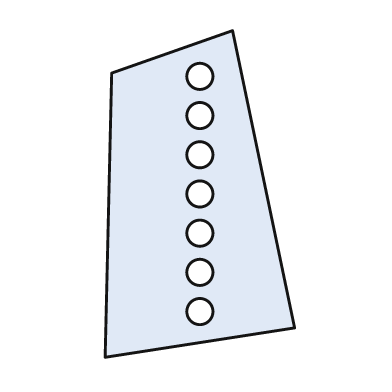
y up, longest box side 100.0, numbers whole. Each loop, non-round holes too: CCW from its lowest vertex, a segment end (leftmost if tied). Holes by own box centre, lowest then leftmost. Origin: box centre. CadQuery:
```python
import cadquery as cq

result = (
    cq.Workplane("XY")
    .moveTo(-29.0, -50.0)
    .lineTo(29.0, -41.0)
    .lineTo(10.0, 50.0)
    .lineTo(-27.0, 37.0)
    .close()
    .moveTo(0.0, -36.0)
    .circle(4.0)
    .moveTo(0.0, -24.0)
    .circle(4.0)
    .moveTo(0.0, -12.0)
    .circle(4.0)
    .moveTo(0.0, 0.0)
    .circle(4.0)
    .moveTo(0.0, 12.0)
    .circle(4.0)
    .moveTo(0.0, 24.0)
    .circle(4.0)
    .moveTo(0.0, 36.0)
    .circle(4.0)
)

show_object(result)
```